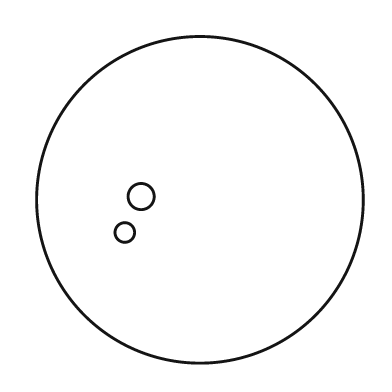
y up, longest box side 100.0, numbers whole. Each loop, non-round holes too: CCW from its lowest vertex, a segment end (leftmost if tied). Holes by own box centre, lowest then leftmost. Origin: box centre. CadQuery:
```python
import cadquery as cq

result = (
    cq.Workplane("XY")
    .moveTo(0.0, 0.0)
    .circle(50.0)
    .moveTo(-23.0, -10.0)
    .circle(3.0)
    .moveTo(-18.0, 1.0)
    .circle(4.0)
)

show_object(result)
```